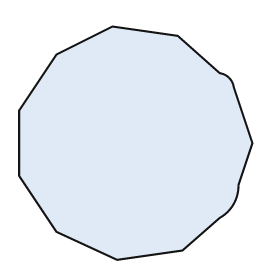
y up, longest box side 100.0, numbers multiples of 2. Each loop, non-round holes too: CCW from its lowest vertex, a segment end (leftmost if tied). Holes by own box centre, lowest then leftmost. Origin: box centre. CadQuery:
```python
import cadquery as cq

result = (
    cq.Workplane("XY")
    .moveTo(-8.0, -50.0)
    .lineTo(20.0, -46.0)
    .lineTo(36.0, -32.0)
    .threePointArc((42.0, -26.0), (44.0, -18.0))
    .lineTo(50.0, 0.0)
    .lineTo(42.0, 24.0)
    .threePointArc((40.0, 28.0), (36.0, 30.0))
    .lineTo(18.0, 46.0)
    .lineTo(-10.0, 50.0)
    .lineTo(-34.0, 38.0)
    .lineTo(-50.0, 14.0)
    .lineTo(-50.0, -14.0)
    .lineTo(-34.0, -38.0)
    .close()
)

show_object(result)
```